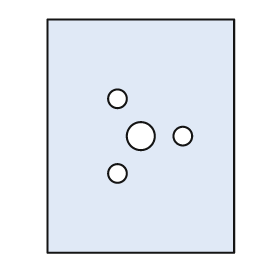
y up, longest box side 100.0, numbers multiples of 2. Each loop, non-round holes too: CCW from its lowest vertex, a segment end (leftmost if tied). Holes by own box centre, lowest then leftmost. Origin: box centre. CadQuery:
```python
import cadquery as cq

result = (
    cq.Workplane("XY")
    .moveTo(-40.0, -50.0)
    .lineTo(40.0, -50.0)
    .lineTo(40.0, 50.0)
    .lineTo(-40.0, 50.0)
    .close()
    .moveTo(-10.0, -16.0)
    .circle(4.0)
    .moveTo(0.0, 0.0)
    .circle(6.0)
    .moveTo(18.0, 0.0)
    .circle(4.0)
    .moveTo(-10.0, 16.0)
    .circle(4.0)
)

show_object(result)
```